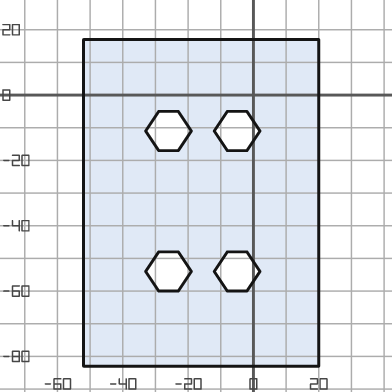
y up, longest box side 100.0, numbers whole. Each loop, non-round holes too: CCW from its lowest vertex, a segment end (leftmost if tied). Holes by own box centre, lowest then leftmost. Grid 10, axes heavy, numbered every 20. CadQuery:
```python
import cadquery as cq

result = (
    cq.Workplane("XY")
    .moveTo(-52.0, -83.0)
    .lineTo(20.0, -83.0)
    .lineTo(20.0, 17.0)
    .lineTo(-52.0, 17.0)
    .close()
    .moveTo(-29.0, -60.0)
    .lineTo(-23.0, -60.0)
    .lineTo(-19.0, -54.0)
    .lineTo(-23.0, -48.0)
    .lineTo(-29.0, -48.0)
    .lineTo(-33.0, -54.0)
    .close()
    .moveTo(-8.0, -60.0)
    .lineTo(-2.0, -60.0)
    .lineTo(2.0, -54.0)
    .lineTo(-2.0, -48.0)
    .lineTo(-8.0, -48.0)
    .lineTo(-12.0, -54.0)
    .close()
    .moveTo(-29.0, -17.0)
    .lineTo(-23.0, -17.0)
    .lineTo(-19.0, -11.0)
    .lineTo(-23.0, -5.0)
    .lineTo(-29.0, -5.0)
    .lineTo(-33.0, -11.0)
    .close()
    .moveTo(-8.0, -17.0)
    .lineTo(-2.0, -17.0)
    .lineTo(2.0, -11.0)
    .lineTo(-2.0, -5.0)
    .lineTo(-8.0, -5.0)
    .lineTo(-12.0, -11.0)
    .close()
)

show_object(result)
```